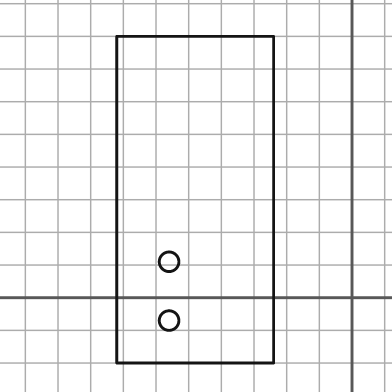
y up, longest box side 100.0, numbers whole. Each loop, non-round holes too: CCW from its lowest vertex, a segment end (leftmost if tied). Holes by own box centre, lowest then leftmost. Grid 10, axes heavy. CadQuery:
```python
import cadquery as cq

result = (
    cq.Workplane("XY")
    .moveTo(-72.0, -20.0)
    .lineTo(-24.0, -20.0)
    .lineTo(-24.0, 80.0)
    .lineTo(-72.0, 80.0)
    .close()
    .moveTo(-56.0, -7.0)
    .circle(3.0)
    .moveTo(-56.0, 11.0)
    .circle(3.0)
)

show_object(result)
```